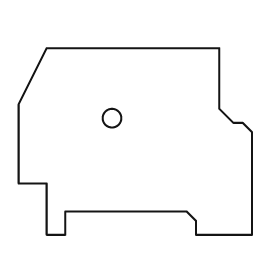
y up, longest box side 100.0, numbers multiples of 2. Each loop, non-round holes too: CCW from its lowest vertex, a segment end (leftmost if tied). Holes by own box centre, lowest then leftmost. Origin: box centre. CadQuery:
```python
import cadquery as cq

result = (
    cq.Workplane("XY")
    .moveTo(-38.0, -40.0)
    .lineTo(-30.0, -40.0)
    .lineTo(-30.0, -30.0)
    .lineTo(22.0, -30.0)
    .lineTo(26.0, -34.0)
    .lineTo(26.0, -40.0)
    .lineTo(50.0, -40.0)
    .lineTo(50.0, 4.0)
    .lineTo(46.0, 8.0)
    .lineTo(42.0, 8.0)
    .lineTo(36.0, 14.0)
    .lineTo(36.0, 40.0)
    .lineTo(-38.0, 40.0)
    .lineTo(-50.0, 16.0)
    .lineTo(-50.0, -18.0)
    .lineTo(-38.0, -18.0)
    .close()
    .moveTo(-10.0, 10.0)
    .circle(4.0)
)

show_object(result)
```